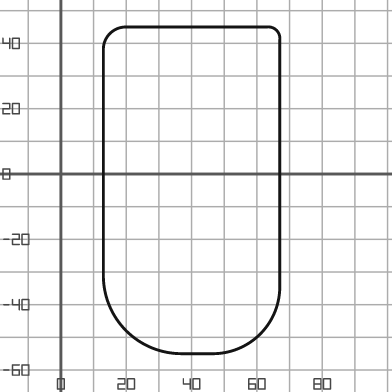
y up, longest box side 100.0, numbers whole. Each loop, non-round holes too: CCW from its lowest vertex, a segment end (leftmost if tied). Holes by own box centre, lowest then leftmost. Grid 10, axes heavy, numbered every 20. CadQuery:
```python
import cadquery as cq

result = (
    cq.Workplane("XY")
    .moveTo(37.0, -55.0)
    .lineTo(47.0, -55.0)
    .threePointArc((61.0, -49.0), (67.0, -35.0))
    .lineTo(67.0, 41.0)
    .threePointArc((66.0, 44.0), (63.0, 45.0))
    .lineTo(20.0, 45.0)
    .threePointArc((15.0, 43.0), (13.0, 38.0))
    .lineTo(13.0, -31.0)
    .threePointArc((20.0, -48.0), (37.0, -55.0))
    .close()
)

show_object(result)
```